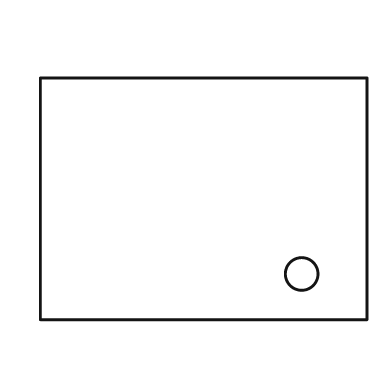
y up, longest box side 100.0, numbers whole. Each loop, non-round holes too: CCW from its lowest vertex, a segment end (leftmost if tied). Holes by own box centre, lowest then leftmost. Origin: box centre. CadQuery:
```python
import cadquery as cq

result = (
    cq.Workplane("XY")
    .moveTo(-50.0, -37.0)
    .lineTo(50.0, -37.0)
    .lineTo(50.0, 37.0)
    .lineTo(-50.0, 37.0)
    .close()
    .moveTo(30.0, -23.0)
    .circle(5.0)
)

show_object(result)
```